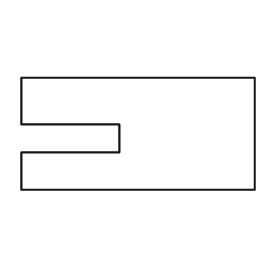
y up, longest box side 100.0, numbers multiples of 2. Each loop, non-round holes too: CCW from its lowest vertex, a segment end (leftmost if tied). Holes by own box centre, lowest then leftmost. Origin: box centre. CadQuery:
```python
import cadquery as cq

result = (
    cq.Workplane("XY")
    .moveTo(-50.0, -24.0)
    .lineTo(50.0, -24.0)
    .lineTo(50.0, 24.0)
    .lineTo(-50.0, 24.0)
    .lineTo(-50.0, 4.0)
    .lineTo(-8.0, 4.0)
    .lineTo(-8.0, -8.0)
    .lineTo(-50.0, -8.0)
    .close()
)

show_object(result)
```